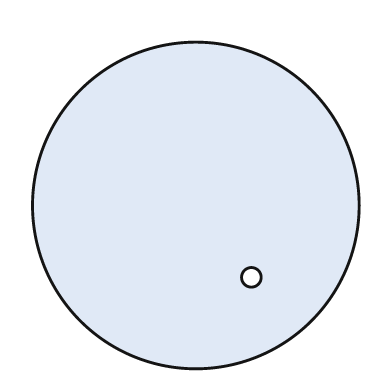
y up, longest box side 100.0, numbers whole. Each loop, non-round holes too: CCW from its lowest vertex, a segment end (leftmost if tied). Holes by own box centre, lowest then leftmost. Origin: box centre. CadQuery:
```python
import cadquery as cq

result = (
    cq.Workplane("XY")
    .moveTo(0.0, 0.0)
    .circle(50.0)
    .moveTo(17.0, -22.0)
    .circle(3.0)
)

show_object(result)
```